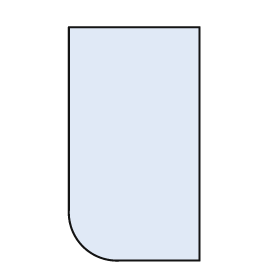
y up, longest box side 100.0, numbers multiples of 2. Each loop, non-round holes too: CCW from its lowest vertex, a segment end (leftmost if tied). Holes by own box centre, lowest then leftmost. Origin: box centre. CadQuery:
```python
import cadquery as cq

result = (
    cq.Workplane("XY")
    .moveTo(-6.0, -50.0)
    .lineTo(28.0, -50.0)
    .lineTo(28.0, 50.0)
    .lineTo(-28.0, 50.0)
    .lineTo(-28.0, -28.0)
    .threePointArc((-22.0, -44.0), (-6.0, -50.0))
    .close()
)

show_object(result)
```